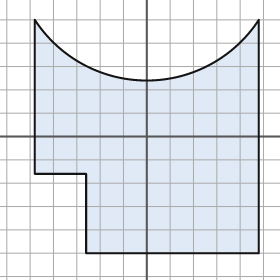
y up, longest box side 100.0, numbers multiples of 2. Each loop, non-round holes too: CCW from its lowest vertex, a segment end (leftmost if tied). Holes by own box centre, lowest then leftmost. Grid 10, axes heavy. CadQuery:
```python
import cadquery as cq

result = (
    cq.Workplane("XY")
    .moveTo(-26.0, -50.0)
    .lineTo(48.0, -50.0)
    .lineTo(48.0, 50.0)
    .threePointArc((0.0, 24.0), (-48.0, 50.0))
    .lineTo(-48.0, -16.0)
    .lineTo(-26.0, -16.0)
    .close()
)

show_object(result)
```